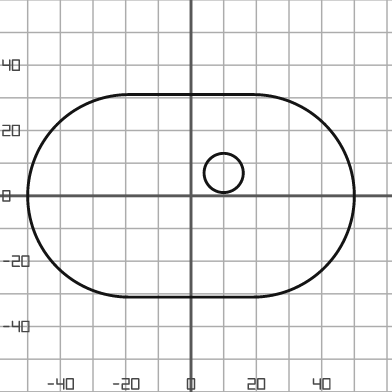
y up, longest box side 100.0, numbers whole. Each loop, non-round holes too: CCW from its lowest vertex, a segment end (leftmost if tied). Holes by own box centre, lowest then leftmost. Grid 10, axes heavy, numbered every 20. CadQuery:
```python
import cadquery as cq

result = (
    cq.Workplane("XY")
    .moveTo(-19.0, -31.0)
    .lineTo(19.0, -31.0)
    .threePointArc((50.0, 0.0), (19.0, 31.0))
    .lineTo(-19.0, 31.0)
    .threePointArc((-50.0, 0.0), (-19.0, -31.0))
    .close()
    .moveTo(10.0, 7.0)
    .circle(6.0)
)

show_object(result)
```